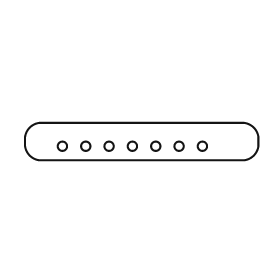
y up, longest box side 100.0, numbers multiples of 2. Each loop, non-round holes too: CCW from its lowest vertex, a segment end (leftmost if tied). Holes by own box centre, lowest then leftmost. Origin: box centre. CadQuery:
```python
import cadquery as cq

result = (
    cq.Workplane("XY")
    .moveTo(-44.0, -8.0)
    .lineTo(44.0, -8.0)
    .threePointArc((48.0, -6.0), (50.0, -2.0))
    .lineTo(50.0, 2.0)
    .threePointArc((48.0, 6.0), (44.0, 8.0))
    .lineTo(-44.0, 8.0)
    .threePointArc((-48.0, 6.0), (-50.0, 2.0))
    .lineTo(-50.0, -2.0)
    .threePointArc((-48.0, -6.0), (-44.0, -8.0))
    .close()
    .moveTo(-34.0, -2.0)
    .circle(2.0)
    .moveTo(-24.0, -2.0)
    .circle(2.0)
    .moveTo(-14.0, -2.0)
    .circle(2.0)
    .moveTo(-4.0, -2.0)
    .circle(2.0)
    .moveTo(6.0, -2.0)
    .circle(2.0)
    .moveTo(16.0, -2.0)
    .circle(2.0)
    .moveTo(26.0, -2.0)
    .circle(2.0)
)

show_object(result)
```